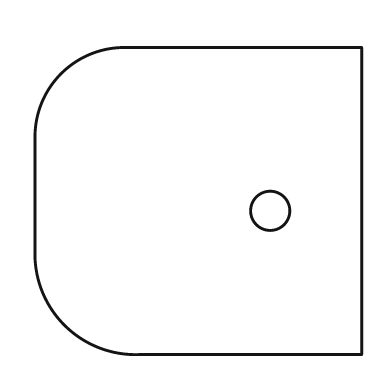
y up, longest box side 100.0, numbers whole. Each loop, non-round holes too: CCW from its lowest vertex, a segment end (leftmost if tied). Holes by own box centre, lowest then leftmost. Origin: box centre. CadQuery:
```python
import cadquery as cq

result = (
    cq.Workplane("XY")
    .moveTo(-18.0, -47.0)
    .lineTo(50.0, -47.0)
    .lineTo(50.0, 47.0)
    .lineTo(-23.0, 47.0)
    .threePointArc((-42.0, 39.0), (-50.0, 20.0))
    .lineTo(-50.0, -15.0)
    .threePointArc((-41.0, -38.0), (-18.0, -47.0))
    .close()
    .moveTo(22.0, -3.0)
    .circle(6.0)
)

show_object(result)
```